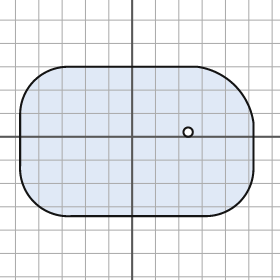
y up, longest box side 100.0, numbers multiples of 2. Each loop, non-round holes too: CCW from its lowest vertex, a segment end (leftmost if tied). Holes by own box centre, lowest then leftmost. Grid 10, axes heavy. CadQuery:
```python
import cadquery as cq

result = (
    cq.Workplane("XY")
    .moveTo(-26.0, -34.0)
    .lineTo(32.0, -34.0)
    .threePointArc((46.0, -28.0), (52.0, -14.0))
    .lineTo(52.0, 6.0)
    .threePointArc((44.0, 22.0), (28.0, 30.0))
    .lineTo(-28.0, 30.0)
    .threePointArc((-42.0, 24.0), (-48.0, 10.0))
    .lineTo(-48.0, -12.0)
    .threePointArc((-42.0, -28.0), (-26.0, -34.0))
    .close()
    .moveTo(24.0, 2.0)
    .circle(2.0)
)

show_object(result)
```